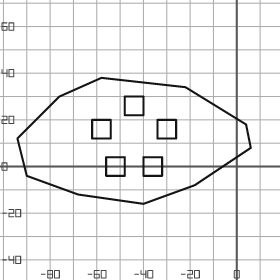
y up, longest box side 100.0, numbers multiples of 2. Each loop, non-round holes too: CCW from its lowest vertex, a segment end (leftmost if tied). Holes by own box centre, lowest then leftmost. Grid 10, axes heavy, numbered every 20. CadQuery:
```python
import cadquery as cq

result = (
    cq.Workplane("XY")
    .moveTo(-40.0, -16.0)
    .lineTo(-18.0, -8.0)
    .lineTo(6.0, 8.0)
    .lineTo(4.0, 18.0)
    .lineTo(-22.0, 34.0)
    .lineTo(-58.0, 38.0)
    .lineTo(-76.0, 30.0)
    .lineTo(-94.0, 12.0)
    .lineTo(-90.0, -4.0)
    .lineTo(-68.0, -12.0)
    .close()
    .moveTo(-56.0, -4.0)
    .lineTo(-48.0, -4.0)
    .lineTo(-48.0, 4.0)
    .lineTo(-56.0, 4.0)
    .close()
    .moveTo(-40.0, -4.0)
    .lineTo(-32.0, -4.0)
    .lineTo(-32.0, 4.0)
    .lineTo(-40.0, 4.0)
    .close()
    .moveTo(-62.0, 12.0)
    .lineTo(-54.0, 12.0)
    .lineTo(-54.0, 20.0)
    .lineTo(-62.0, 20.0)
    .close()
    .moveTo(-34.0, 12.0)
    .lineTo(-26.0, 12.0)
    .lineTo(-26.0, 20.0)
    .lineTo(-34.0, 20.0)
    .close()
    .moveTo(-48.0, 22.0)
    .lineTo(-40.0, 22.0)
    .lineTo(-40.0, 30.0)
    .lineTo(-48.0, 30.0)
    .close()
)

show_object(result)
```